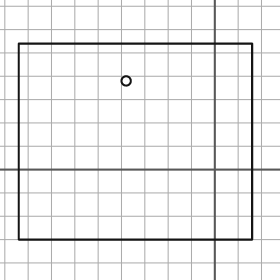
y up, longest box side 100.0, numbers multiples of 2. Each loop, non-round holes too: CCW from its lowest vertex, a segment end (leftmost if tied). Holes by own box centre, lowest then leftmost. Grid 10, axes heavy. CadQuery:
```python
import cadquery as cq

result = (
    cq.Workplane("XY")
    .moveTo(-84.0, -30.0)
    .lineTo(16.0, -30.0)
    .lineTo(16.0, 54.0)
    .lineTo(-84.0, 54.0)
    .close()
    .moveTo(-38.0, 38.0)
    .circle(2.0)
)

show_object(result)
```